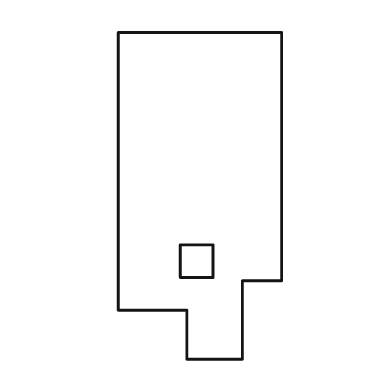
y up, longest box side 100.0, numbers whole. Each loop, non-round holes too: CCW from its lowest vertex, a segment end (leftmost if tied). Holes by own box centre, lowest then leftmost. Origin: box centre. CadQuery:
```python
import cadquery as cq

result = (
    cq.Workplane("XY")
    .moveTo(-4.0, -50.0)
    .lineTo(13.0, -50.0)
    .lineTo(13.0, -26.0)
    .lineTo(25.0, -26.0)
    .lineTo(25.0, 50.0)
    .lineTo(-25.0, 50.0)
    .lineTo(-25.0, -35.0)
    .lineTo(-4.0, -35.0)
    .close()
    .moveTo(-6.0, -25.0)
    .lineTo(4.0, -25.0)
    .lineTo(4.0, -15.0)
    .lineTo(-6.0, -15.0)
    .close()
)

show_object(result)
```